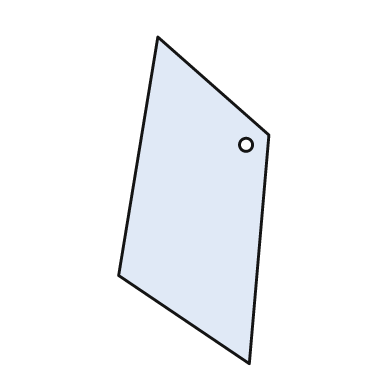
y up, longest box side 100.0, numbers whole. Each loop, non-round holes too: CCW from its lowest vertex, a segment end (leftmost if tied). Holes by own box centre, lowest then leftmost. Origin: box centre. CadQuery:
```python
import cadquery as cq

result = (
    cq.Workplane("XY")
    .moveTo(17.0, -50.0)
    .lineTo(23.0, 20.0)
    .lineTo(-11.0, 50.0)
    .lineTo(-23.0, -23.0)
    .close()
    .moveTo(16.0, 17.0)
    .circle(2.0)
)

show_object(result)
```